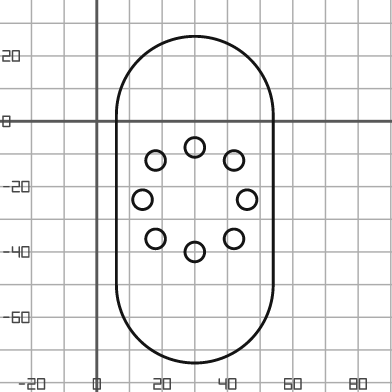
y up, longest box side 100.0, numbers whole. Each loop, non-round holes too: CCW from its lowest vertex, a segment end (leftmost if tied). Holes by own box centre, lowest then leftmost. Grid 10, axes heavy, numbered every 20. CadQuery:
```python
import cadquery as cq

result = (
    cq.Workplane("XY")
    .moveTo(6.0, -50.0)
    .threePointArc((30.0, -74.0), (54.0, -50.0))
    .lineTo(54.0, 2.0)
    .threePointArc((30.0, 26.0), (6.0, 2.0))
    .close()
    .moveTo(30.0, -40.0)
    .circle(3.0)
    .moveTo(18.0, -36.0)
    .circle(3.0)
    .moveTo(42.0, -36.0)
    .circle(3.0)
    .moveTo(14.0, -24.0)
    .circle(3.0)
    .moveTo(46.0, -24.0)
    .circle(3.0)
    .moveTo(18.0, -12.0)
    .circle(3.0)
    .moveTo(42.0, -12.0)
    .circle(3.0)
    .moveTo(30.0, -8.0)
    .circle(3.0)
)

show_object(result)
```